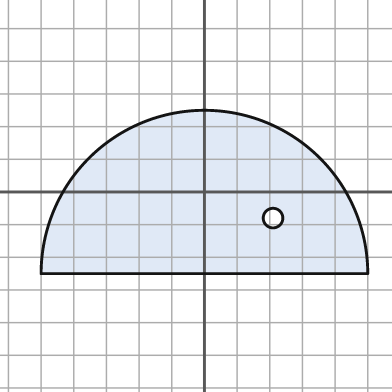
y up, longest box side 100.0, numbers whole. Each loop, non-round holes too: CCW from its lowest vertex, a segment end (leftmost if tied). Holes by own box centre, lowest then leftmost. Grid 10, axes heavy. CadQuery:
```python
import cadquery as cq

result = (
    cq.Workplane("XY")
    .moveTo(-50.0, -25.0)
    .lineTo(50.0, -25.0)
    .threePointArc((0.0, 25.0), (-50.0, -25.0))
    .close()
    .moveTo(21.0, -8.0)
    .circle(3.0)
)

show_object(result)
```